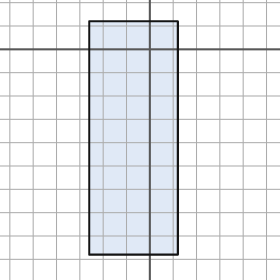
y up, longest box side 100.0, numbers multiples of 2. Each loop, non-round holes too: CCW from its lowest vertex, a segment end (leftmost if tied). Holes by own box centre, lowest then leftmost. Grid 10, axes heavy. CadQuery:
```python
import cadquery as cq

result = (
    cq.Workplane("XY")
    .moveTo(-26.0, -88.0)
    .lineTo(12.0, -88.0)
    .lineTo(12.0, 12.0)
    .lineTo(-26.0, 12.0)
    .close()
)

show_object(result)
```